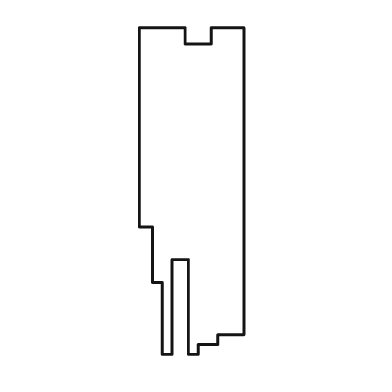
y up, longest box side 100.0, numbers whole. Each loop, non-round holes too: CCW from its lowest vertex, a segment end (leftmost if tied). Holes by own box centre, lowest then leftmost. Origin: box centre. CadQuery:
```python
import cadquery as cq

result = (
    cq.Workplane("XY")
    .moveTo(-9.0, -50.0)
    .lineTo(-6.0, -50.0)
    .lineTo(-6.0, -21.0)
    .lineTo(-1.0, -21.0)
    .lineTo(-1.0, -50.0)
    .lineTo(2.0, -50.0)
    .lineTo(2.0, -47.0)
    .lineTo(8.0, -47.0)
    .lineTo(8.0, -44.0)
    .lineTo(16.0, -44.0)
    .lineTo(16.0, 50.0)
    .lineTo(6.0, 50.0)
    .lineTo(6.0, 45.0)
    .lineTo(-2.0, 45.0)
    .lineTo(-2.0, 50.0)
    .lineTo(-16.0, 50.0)
    .lineTo(-16.0, -11.0)
    .lineTo(-12.0, -11.0)
    .lineTo(-12.0, -28.0)
    .lineTo(-9.0, -28.0)
    .close()
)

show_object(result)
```